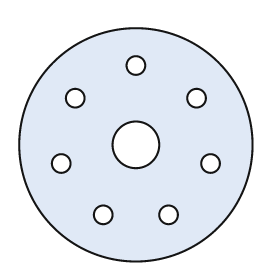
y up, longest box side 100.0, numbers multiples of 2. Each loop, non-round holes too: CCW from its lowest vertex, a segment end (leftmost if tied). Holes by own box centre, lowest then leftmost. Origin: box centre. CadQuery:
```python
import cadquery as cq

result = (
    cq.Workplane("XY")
    .moveTo(0.0, 0.0)
    .circle(50.0)
    .moveTo(-14.0, -30.0)
    .circle(4.0)
    .moveTo(14.0, -30.0)
    .circle(4.0)
    .moveTo(-32.0, -8.0)
    .circle(4.0)
    .moveTo(32.0, -8.0)
    .circle(4.0)
    .moveTo(0.0, 0.0)
    .circle(10.0)
    .moveTo(-26.0, 20.0)
    .circle(4.0)
    .moveTo(26.0, 20.0)
    .circle(4.0)
    .moveTo(0.0, 34.0)
    .circle(4.0)
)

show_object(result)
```